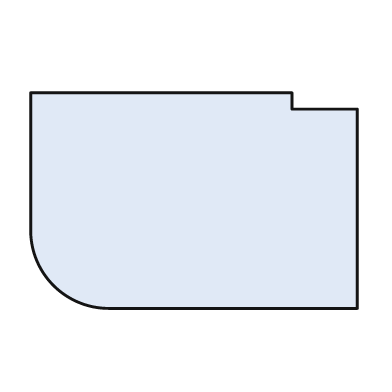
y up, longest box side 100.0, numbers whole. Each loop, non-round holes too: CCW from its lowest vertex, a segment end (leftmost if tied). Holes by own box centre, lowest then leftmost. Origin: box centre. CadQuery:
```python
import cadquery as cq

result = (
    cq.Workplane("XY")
    .moveTo(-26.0, -33.0)
    .lineTo(50.0, -33.0)
    .lineTo(50.0, 28.0)
    .lineTo(30.0, 28.0)
    .lineTo(30.0, 33.0)
    .lineTo(-50.0, 33.0)
    .lineTo(-50.0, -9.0)
    .threePointArc((-43.0, -26.0), (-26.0, -33.0))
    .close()
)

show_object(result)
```